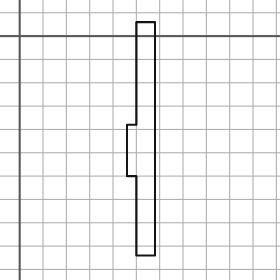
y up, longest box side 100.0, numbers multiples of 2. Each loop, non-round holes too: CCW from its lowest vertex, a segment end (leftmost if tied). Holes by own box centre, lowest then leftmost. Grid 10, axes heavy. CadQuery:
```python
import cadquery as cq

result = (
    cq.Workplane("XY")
    .moveTo(50.0, -94.0)
    .lineTo(58.0, -94.0)
    .lineTo(58.0, 6.0)
    .lineTo(50.0, 6.0)
    .lineTo(50.0, -38.0)
    .lineTo(46.0, -38.0)
    .lineTo(46.0, -60.0)
    .lineTo(50.0, -60.0)
    .close()
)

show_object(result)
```